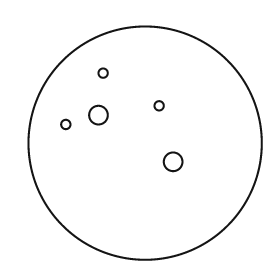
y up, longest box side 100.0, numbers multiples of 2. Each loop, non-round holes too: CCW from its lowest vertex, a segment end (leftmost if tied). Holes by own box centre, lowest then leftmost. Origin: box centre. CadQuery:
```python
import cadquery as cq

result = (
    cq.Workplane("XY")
    .moveTo(0.0, 0.0)
    .circle(50.0)
    .moveTo(12.0, -8.0)
    .circle(4.0)
    .moveTo(-34.0, 8.0)
    .circle(2.0)
    .moveTo(-20.0, 12.0)
    .circle(4.0)
    .moveTo(6.0, 16.0)
    .circle(2.0)
    .moveTo(-18.0, 30.0)
    .circle(2.0)
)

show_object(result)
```